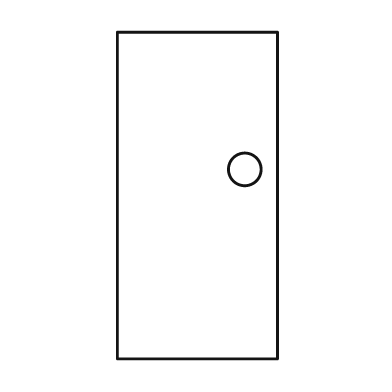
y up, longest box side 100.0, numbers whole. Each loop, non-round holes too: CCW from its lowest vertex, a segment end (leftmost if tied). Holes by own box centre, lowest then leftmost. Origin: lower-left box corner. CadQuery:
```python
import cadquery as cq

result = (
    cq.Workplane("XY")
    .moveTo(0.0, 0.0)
    .lineTo(49.0, 0.0)
    .lineTo(49.0, 100.0)
    .lineTo(0.0, 100.0)
    .close()
    .moveTo(39.0, 58.0)
    .circle(5.0)
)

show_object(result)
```